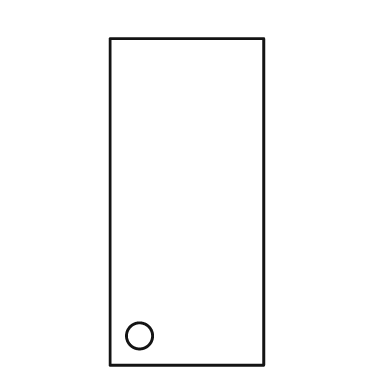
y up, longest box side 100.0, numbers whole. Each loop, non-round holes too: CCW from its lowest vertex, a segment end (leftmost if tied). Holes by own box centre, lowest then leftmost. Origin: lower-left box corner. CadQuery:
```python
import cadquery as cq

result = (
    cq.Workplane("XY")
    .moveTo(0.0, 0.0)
    .lineTo(47.0, 0.0)
    .lineTo(47.0, 100.0)
    .lineTo(0.0, 100.0)
    .close()
    .moveTo(9.0, 9.0)
    .circle(4.0)
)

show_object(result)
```